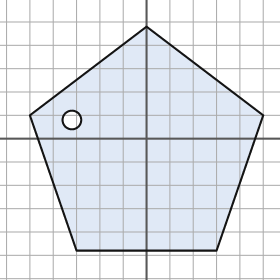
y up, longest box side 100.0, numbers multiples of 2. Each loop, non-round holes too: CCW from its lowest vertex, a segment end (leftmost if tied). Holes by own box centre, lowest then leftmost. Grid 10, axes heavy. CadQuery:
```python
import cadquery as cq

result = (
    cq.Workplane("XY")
    .moveTo(-30.0, -48.0)
    .lineTo(30.0, -48.0)
    .lineTo(50.0, 10.0)
    .lineTo(0.0, 48.0)
    .lineTo(-50.0, 10.0)
    .close()
    .moveTo(-32.0, 8.0)
    .circle(4.0)
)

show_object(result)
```